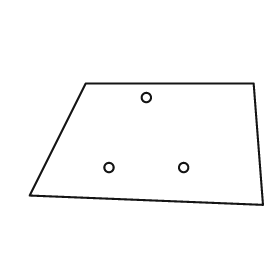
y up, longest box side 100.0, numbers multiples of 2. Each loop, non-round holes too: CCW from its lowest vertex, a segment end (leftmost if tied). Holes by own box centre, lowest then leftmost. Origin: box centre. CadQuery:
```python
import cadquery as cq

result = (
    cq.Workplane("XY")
    .moveTo(50.0, -26.0)
    .lineTo(46.0, 26.0)
    .lineTo(-26.0, 26.0)
    .lineTo(-50.0, -22.0)
    .close()
    .moveTo(-16.0, -10.0)
    .circle(2.0)
    .moveTo(16.0, -10.0)
    .circle(2.0)
    .moveTo(0.0, 20.0)
    .circle(2.0)
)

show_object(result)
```